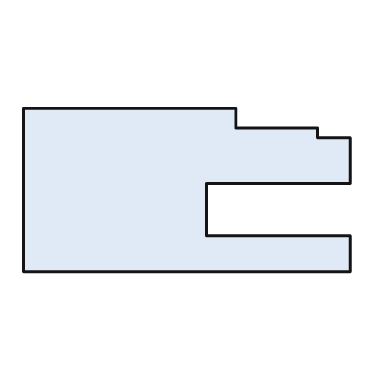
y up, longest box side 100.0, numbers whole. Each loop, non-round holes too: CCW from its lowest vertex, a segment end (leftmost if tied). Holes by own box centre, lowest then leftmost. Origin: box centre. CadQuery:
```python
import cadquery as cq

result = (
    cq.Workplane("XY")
    .moveTo(-50.0, -25.0)
    .lineTo(50.0, -25.0)
    .lineTo(50.0, -14.0)
    .lineTo(6.0, -14.0)
    .lineTo(6.0, 2.0)
    .lineTo(50.0, 2.0)
    .lineTo(50.0, 16.0)
    .lineTo(40.0, 16.0)
    .lineTo(40.0, 19.0)
    .lineTo(15.0, 19.0)
    .lineTo(15.0, 25.0)
    .lineTo(-50.0, 25.0)
    .close()
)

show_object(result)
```